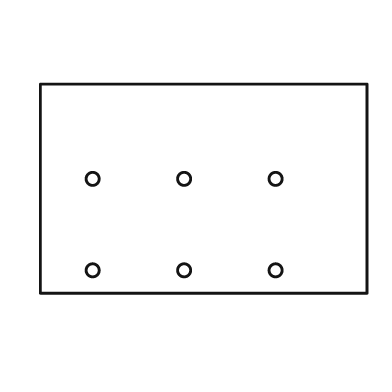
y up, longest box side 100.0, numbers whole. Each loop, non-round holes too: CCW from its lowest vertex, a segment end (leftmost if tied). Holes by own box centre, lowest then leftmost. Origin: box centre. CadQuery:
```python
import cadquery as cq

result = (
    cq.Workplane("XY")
    .moveTo(-50.0, -32.0)
    .lineTo(50.0, -32.0)
    .lineTo(50.0, 32.0)
    .lineTo(-50.0, 32.0)
    .close()
    .moveTo(-34.0, -25.0)
    .circle(2.0)
    .moveTo(-6.0, -25.0)
    .circle(2.0)
    .moveTo(22.0, -25.0)
    .circle(2.0)
    .moveTo(-34.0, 3.0)
    .circle(2.0)
    .moveTo(-6.0, 3.0)
    .circle(2.0)
    .moveTo(22.0, 3.0)
    .circle(2.0)
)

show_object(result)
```